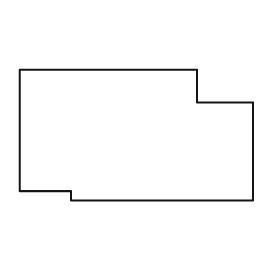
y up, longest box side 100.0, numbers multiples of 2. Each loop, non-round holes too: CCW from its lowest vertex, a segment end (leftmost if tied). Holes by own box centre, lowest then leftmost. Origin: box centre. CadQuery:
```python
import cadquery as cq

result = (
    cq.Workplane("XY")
    .moveTo(-28.0, -28.0)
    .lineTo(50.0, -28.0)
    .lineTo(50.0, 14.0)
    .lineTo(26.0, 14.0)
    .lineTo(26.0, 28.0)
    .lineTo(-50.0, 28.0)
    .lineTo(-50.0, -24.0)
    .lineTo(-28.0, -24.0)
    .close()
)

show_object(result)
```